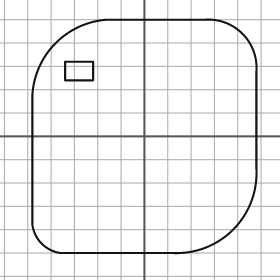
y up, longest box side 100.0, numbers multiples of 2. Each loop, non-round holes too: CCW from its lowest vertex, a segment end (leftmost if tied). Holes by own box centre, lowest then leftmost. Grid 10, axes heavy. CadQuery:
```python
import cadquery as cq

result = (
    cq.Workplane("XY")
    .moveTo(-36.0, -50.0)
    .lineTo(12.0, -50.0)
    .threePointArc((38.0, -40.0), (48.0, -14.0))
    .lineTo(48.0, 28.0)
    .threePointArc((42.0, 44.0), (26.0, 50.0))
    .lineTo(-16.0, 50.0)
    .threePointArc((-38.0, 40.0), (-48.0, 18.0))
    .lineTo(-48.0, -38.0)
    .threePointArc((-44.0, -46.0), (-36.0, -50.0))
    .close()
    .moveTo(-34.0, 24.0)
    .lineTo(-22.0, 24.0)
    .lineTo(-22.0, 32.0)
    .lineTo(-34.0, 32.0)
    .close()
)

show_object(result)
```